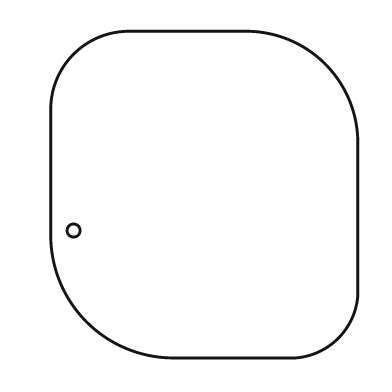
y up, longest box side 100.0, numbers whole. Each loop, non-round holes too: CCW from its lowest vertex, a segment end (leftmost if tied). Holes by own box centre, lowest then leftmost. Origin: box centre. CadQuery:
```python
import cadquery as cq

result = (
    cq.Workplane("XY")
    .moveTo(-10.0, -50.0)
    .lineTo(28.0, -50.0)
    .threePointArc((41.0, -44.0), (47.0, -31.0))
    .lineTo(47.0, 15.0)
    .threePointArc((37.0, 40.0), (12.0, 50.0))
    .lineTo(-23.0, 50.0)
    .threePointArc((-40.0, 43.0), (-47.0, 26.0))
    .lineTo(-47.0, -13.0)
    .threePointArc((-36.0, -39.0), (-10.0, -50.0))
    .close()
    .moveTo(-40.0, -11.0)
    .circle(2.0)
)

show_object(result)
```